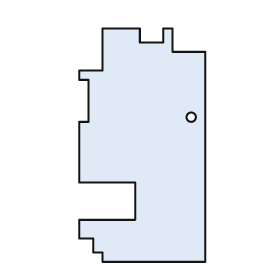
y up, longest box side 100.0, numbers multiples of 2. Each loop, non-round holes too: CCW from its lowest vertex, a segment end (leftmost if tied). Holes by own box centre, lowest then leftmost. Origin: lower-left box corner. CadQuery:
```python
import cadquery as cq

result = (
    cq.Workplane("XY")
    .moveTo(10.0, 0.0)
    .lineTo(54.0, 0.0)
    .lineTo(54.0, 90.0)
    .lineTo(40.0, 90.0)
    .lineTo(40.0, 100.0)
    .lineTo(36.0, 100.0)
    .lineTo(36.0, 94.0)
    .lineTo(26.0, 94.0)
    .lineTo(26.0, 100.0)
    .lineTo(10.0, 100.0)
    .lineTo(10.0, 82.0)
    .lineTo(0.0, 82.0)
    .lineTo(0.0, 78.0)
    .lineTo(4.0, 78.0)
    .lineTo(4.0, 60.0)
    .lineTo(0.0, 60.0)
    .lineTo(0.0, 34.0)
    .lineTo(24.0, 34.0)
    .lineTo(24.0, 18.0)
    .lineTo(0.0, 18.0)
    .lineTo(0.0, 10.0)
    .lineTo(6.0, 10.0)
    .lineTo(6.0, 4.0)
    .lineTo(10.0, 4.0)
    .close()
    .moveTo(48.0, 62.0)
    .circle(2.0)
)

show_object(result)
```